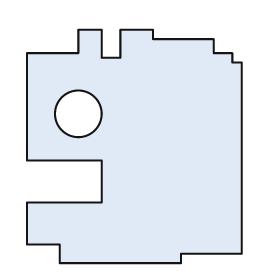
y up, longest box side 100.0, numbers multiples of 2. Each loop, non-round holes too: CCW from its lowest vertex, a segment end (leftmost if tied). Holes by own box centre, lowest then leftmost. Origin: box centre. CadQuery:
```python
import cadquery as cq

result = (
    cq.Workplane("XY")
    .moveTo(-32.0, -50.0)
    .lineTo(20.0, -50.0)
    .lineTo(20.0, -46.0)
    .lineTo(46.0, -46.0)
    .lineTo(46.0, 36.0)
    .lineTo(42.0, 36.0)
    .lineTo(42.0, 40.0)
    .lineTo(34.0, 40.0)
    .lineTo(34.0, 46.0)
    .lineTo(8.0, 46.0)
    .lineTo(8.0, 50.0)
    .lineTo(-6.0, 50.0)
    .lineTo(-6.0, 38.0)
    .lineTo(-14.0, 38.0)
    .lineTo(-14.0, 50.0)
    .lineTo(-24.0, 50.0)
    .lineTo(-24.0, 40.0)
    .lineTo(-46.0, 40.0)
    .lineTo(-46.0, -6.0)
    .lineTo(-14.0, -6.0)
    .lineTo(-14.0, -24.0)
    .lineTo(-46.0, -24.0)
    .lineTo(-46.0, -42.0)
    .lineTo(-32.0, -42.0)
    .close()
    .moveTo(-24.0, 14.0)
    .circle(10.0)
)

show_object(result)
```